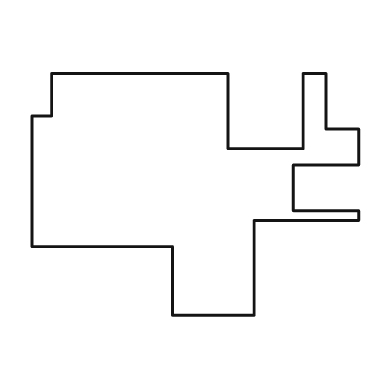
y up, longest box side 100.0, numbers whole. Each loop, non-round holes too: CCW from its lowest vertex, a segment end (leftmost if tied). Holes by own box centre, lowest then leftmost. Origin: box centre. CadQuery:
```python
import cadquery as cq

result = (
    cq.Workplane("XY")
    .moveTo(-7.0, -37.0)
    .lineTo(18.0, -37.0)
    .lineTo(18.0, -8.0)
    .lineTo(50.0, -8.0)
    .lineTo(50.0, -5.0)
    .lineTo(30.0, -5.0)
    .lineTo(30.0, 9.0)
    .lineTo(50.0, 9.0)
    .lineTo(50.0, 20.0)
    .lineTo(40.0, 20.0)
    .lineTo(40.0, 37.0)
    .lineTo(33.0, 37.0)
    .lineTo(33.0, 14.0)
    .lineTo(10.0, 14.0)
    .lineTo(10.0, 37.0)
    .lineTo(-44.0, 37.0)
    .lineTo(-44.0, 24.0)
    .lineTo(-50.0, 24.0)
    .lineTo(-50.0, -16.0)
    .lineTo(-7.0, -16.0)
    .close()
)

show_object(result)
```